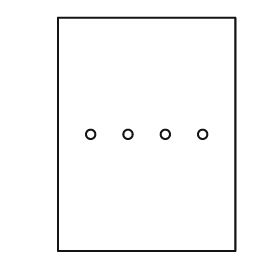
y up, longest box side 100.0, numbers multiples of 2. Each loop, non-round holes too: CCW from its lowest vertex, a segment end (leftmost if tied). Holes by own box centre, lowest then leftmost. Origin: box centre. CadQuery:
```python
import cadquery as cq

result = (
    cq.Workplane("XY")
    .moveTo(-38.0, -50.0)
    .lineTo(38.0, -50.0)
    .lineTo(38.0, 50.0)
    .lineTo(-38.0, 50.0)
    .close()
    .moveTo(-24.0, 0.0)
    .circle(2.0)
    .moveTo(-8.0, 0.0)
    .circle(2.0)
    .moveTo(8.0, 0.0)
    .circle(2.0)
    .moveTo(24.0, 0.0)
    .circle(2.0)
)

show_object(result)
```